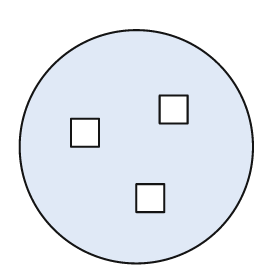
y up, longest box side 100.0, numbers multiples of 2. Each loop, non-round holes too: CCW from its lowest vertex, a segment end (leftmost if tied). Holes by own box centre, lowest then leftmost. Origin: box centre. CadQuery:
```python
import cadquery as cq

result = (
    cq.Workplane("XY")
    .moveTo(0.0, 0.0)
    .circle(50.0)
    .moveTo(0.0, -28.0)
    .lineTo(12.0, -28.0)
    .lineTo(12.0, -16.0)
    .lineTo(0.0, -16.0)
    .close()
    .moveTo(-28.0, 0.0)
    .lineTo(-16.0, 0.0)
    .lineTo(-16.0, 12.0)
    .lineTo(-28.0, 12.0)
    .close()
    .moveTo(10.0, 10.0)
    .lineTo(22.0, 10.0)
    .lineTo(22.0, 22.0)
    .lineTo(10.0, 22.0)
    .close()
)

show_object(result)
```